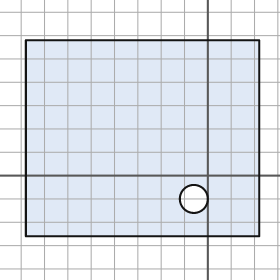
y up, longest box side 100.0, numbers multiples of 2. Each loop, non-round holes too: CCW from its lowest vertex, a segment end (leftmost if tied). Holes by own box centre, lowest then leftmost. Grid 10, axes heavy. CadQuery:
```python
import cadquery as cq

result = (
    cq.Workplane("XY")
    .moveTo(-78.0, -26.0)
    .lineTo(22.0, -26.0)
    .lineTo(22.0, 58.0)
    .lineTo(-78.0, 58.0)
    .close()
    .moveTo(-6.0, -10.0)
    .circle(6.0)
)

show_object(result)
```